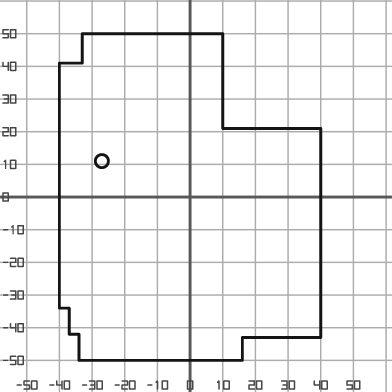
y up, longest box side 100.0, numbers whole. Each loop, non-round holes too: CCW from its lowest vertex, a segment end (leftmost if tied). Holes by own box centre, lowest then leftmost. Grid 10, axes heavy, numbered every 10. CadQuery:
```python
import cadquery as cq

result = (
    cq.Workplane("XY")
    .moveTo(-34.0, -50.0)
    .lineTo(16.0, -50.0)
    .lineTo(16.0, -43.0)
    .lineTo(40.0, -43.0)
    .lineTo(40.0, 21.0)
    .lineTo(10.0, 21.0)
    .lineTo(10.0, 50.0)
    .lineTo(-33.0, 50.0)
    .lineTo(-33.0, 41.0)
    .lineTo(-40.0, 41.0)
    .lineTo(-40.0, -34.0)
    .lineTo(-37.0, -34.0)
    .lineTo(-37.0, -42.0)
    .lineTo(-34.0, -42.0)
    .close()
    .moveTo(-27.0, 11.0)
    .circle(2.0)
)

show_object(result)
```